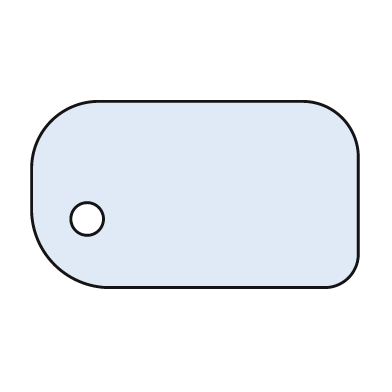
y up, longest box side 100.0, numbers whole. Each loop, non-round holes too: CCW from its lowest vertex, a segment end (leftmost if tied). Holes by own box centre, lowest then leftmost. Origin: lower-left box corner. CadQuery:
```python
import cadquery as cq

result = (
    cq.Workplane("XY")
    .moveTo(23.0, 0.0)
    .lineTo(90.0, 0.0)
    .threePointArc((97.0, 3.0), (100.0, 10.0))
    .lineTo(100.0, 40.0)
    .threePointArc((95.0, 52.0), (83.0, 57.0))
    .lineTo(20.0, 57.0)
    .threePointArc((6.0, 51.0), (0.0, 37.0))
    .lineTo(0.0, 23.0)
    .threePointArc((7.0, 7.0), (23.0, 0.0))
    .close()
    .moveTo(17.0, 21.0)
    .circle(5.0)
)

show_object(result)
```